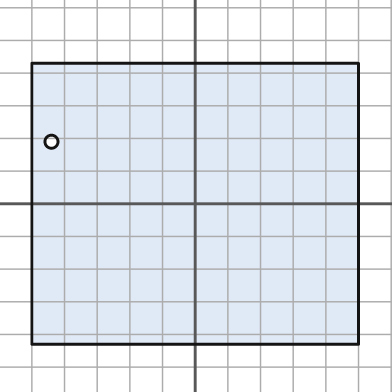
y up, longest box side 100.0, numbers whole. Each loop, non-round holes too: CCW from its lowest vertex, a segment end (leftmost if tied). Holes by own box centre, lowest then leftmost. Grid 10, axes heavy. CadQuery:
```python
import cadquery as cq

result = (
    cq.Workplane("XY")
    .moveTo(-50.0, -43.0)
    .lineTo(50.0, -43.0)
    .lineTo(50.0, 43.0)
    .lineTo(-50.0, 43.0)
    .close()
    .moveTo(-44.0, 19.0)
    .circle(2.0)
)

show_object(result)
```